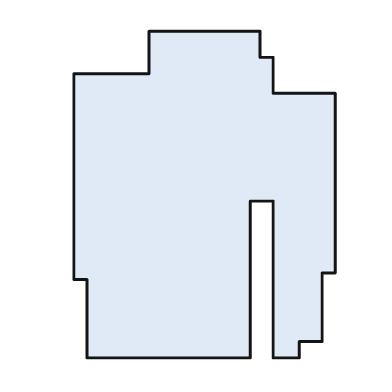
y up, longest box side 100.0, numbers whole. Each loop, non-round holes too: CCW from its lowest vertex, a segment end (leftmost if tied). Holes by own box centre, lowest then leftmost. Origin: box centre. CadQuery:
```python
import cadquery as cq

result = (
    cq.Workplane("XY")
    .moveTo(-36.0, -50.0)
    .lineTo(14.0, -50.0)
    .lineTo(14.0, -2.0)
    .lineTo(21.0, -2.0)
    .lineTo(21.0, -50.0)
    .lineTo(29.0, -50.0)
    .lineTo(29.0, -45.0)
    .lineTo(36.0, -45.0)
    .lineTo(36.0, -24.0)
    .lineTo(40.0, -24.0)
    .lineTo(40.0, 31.0)
    .lineTo(21.0, 31.0)
    .lineTo(21.0, 42.0)
    .lineTo(17.0, 42.0)
    .lineTo(17.0, 50.0)
    .lineTo(-17.0, 50.0)
    .lineTo(-17.0, 37.0)
    .lineTo(-40.0, 37.0)
    .lineTo(-40.0, -26.0)
    .lineTo(-36.0, -26.0)
    .close()
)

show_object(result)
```